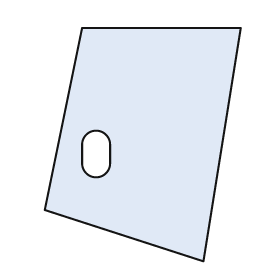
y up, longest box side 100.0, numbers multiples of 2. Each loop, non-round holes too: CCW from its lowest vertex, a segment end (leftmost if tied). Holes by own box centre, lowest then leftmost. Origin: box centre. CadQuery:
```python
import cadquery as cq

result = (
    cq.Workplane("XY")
    .moveTo(26.0, -50.0)
    .lineTo(42.0, 50.0)
    .lineTo(-26.0, 50.0)
    .lineTo(-42.0, -28.0)
    .close()
    .moveTo(-26.0, -8.0)
    .threePointArc((-20.0, -14.0), (-14.0, -8.0))
    .lineTo(-14.0, 0.0)
    .threePointArc((-20.0, 6.0), (-26.0, 0.0))
    .close()
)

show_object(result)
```